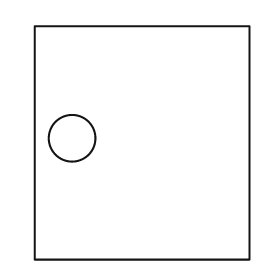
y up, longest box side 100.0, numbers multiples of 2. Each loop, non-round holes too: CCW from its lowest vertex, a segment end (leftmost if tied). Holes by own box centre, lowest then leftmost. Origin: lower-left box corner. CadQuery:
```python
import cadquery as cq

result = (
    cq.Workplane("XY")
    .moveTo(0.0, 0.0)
    .lineTo(92.0, 0.0)
    .lineTo(92.0, 100.0)
    .lineTo(0.0, 100.0)
    .close()
    .moveTo(16.0, 52.0)
    .circle(10.0)
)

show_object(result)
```